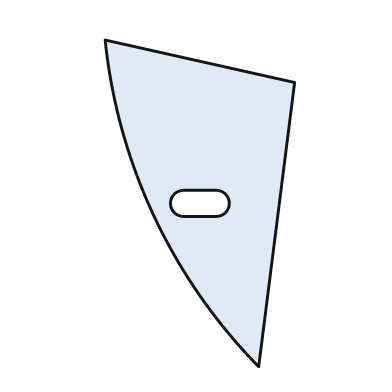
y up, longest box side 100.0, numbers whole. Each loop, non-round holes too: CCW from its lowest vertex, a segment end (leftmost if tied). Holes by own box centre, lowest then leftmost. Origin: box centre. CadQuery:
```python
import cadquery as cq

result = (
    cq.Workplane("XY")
    .moveTo(18.0, -50.0)
    .lineTo(29.0, 37.0)
    .lineTo(-29.0, 50.0)
    .threePointArc((-14.0, -4.0), (18.0, -50.0))
    .close()
    .moveTo(-5.0, -4.0)
    .lineTo(5.0, -4.0)
    .threePointArc((9.0, 0.0), (5.0, 4.0))
    .lineTo(-5.0, 4.0)
    .threePointArc((-9.0, 0.0), (-5.0, -4.0))
    .close()
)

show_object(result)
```